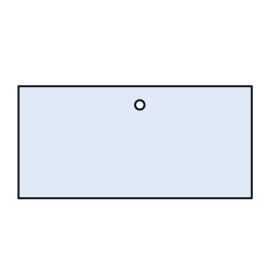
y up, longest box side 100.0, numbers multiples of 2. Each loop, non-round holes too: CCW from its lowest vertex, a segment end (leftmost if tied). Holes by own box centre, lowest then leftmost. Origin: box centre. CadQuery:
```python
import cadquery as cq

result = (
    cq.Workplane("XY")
    .moveTo(-50.0, -24.0)
    .lineTo(50.0, -24.0)
    .lineTo(50.0, 24.0)
    .lineTo(-50.0, 24.0)
    .close()
    .moveTo(2.0, 16.0)
    .circle(2.0)
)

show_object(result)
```